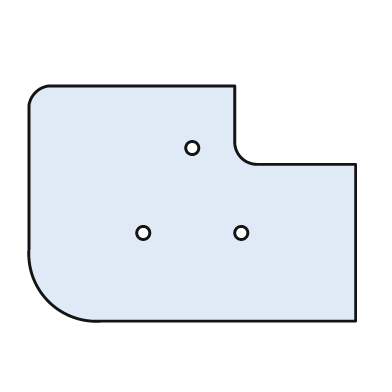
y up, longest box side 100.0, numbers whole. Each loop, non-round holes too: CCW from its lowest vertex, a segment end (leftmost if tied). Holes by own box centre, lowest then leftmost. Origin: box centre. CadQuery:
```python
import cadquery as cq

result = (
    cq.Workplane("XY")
    .moveTo(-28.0, -36.0)
    .lineTo(50.0, -36.0)
    .lineTo(50.0, 12.0)
    .lineTo(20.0, 12.0)
    .threePointArc((15.0, 14.0), (13.0, 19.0))
    .lineTo(13.0, 36.0)
    .lineTo(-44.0, 36.0)
    .threePointArc((-48.0, 34.0), (-50.0, 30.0))
    .lineTo(-50.0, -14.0)
    .threePointArc((-44.0, -30.0), (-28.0, -36.0))
    .close()
    .moveTo(-15.0, -9.0)
    .circle(2.0)
    .moveTo(15.0, -9.0)
    .circle(2.0)
    .moveTo(0.0, 17.0)
    .circle(2.0)
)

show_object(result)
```